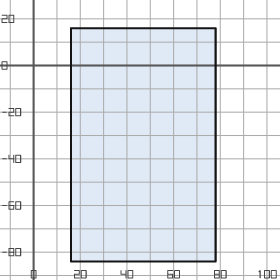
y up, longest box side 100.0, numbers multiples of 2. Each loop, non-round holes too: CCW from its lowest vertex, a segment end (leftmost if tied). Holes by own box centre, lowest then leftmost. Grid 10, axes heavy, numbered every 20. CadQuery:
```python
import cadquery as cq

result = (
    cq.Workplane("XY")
    .moveTo(16.0, -84.0)
    .lineTo(78.0, -84.0)
    .lineTo(78.0, 16.0)
    .lineTo(16.0, 16.0)
    .close()
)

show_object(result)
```